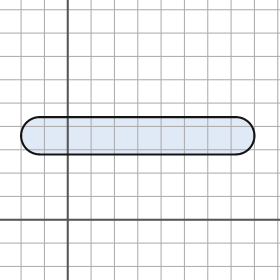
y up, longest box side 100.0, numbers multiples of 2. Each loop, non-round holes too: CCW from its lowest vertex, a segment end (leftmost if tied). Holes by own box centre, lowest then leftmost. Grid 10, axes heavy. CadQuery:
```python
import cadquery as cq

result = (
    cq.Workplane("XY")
    .moveTo(-12.0, 28.0)
    .lineTo(72.0, 28.0)
    .threePointArc((80.0, 36.0), (72.0, 44.0))
    .lineTo(-12.0, 44.0)
    .threePointArc((-20.0, 36.0), (-12.0, 28.0))
    .close()
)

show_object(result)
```